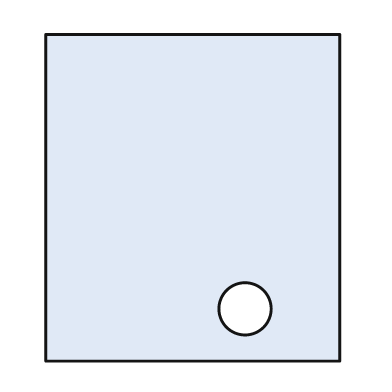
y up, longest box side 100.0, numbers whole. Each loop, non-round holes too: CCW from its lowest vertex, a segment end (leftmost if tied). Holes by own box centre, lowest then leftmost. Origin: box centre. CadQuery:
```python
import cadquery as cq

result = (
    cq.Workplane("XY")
    .moveTo(-45.0, -50.0)
    .lineTo(45.0, -50.0)
    .lineTo(45.0, 50.0)
    .lineTo(-45.0, 50.0)
    .close()
    .moveTo(16.0, -34.0)
    .circle(8.0)
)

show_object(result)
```